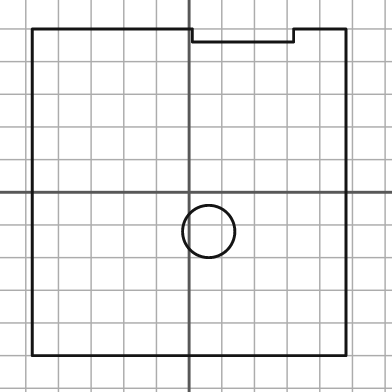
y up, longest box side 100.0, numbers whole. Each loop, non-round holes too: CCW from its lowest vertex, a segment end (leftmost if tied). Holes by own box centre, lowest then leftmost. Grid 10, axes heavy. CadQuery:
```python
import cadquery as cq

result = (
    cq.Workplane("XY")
    .moveTo(-48.0, -50.0)
    .lineTo(48.0, -50.0)
    .lineTo(48.0, 50.0)
    .lineTo(32.0, 50.0)
    .lineTo(32.0, 46.0)
    .lineTo(1.0, 46.0)
    .lineTo(1.0, 50.0)
    .lineTo(-48.0, 50.0)
    .close()
    .moveTo(6.0, -12.0)
    .circle(8.0)
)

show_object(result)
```